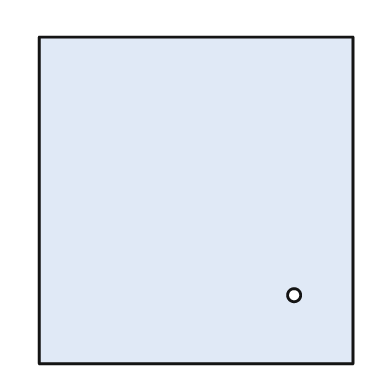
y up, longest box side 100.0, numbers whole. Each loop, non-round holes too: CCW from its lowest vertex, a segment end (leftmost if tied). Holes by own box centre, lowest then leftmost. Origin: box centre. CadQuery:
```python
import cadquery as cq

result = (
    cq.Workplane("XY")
    .moveTo(-48.0, -50.0)
    .lineTo(48.0, -50.0)
    .lineTo(48.0, 50.0)
    .lineTo(-48.0, 50.0)
    .close()
    .moveTo(30.0, -29.0)
    .circle(2.0)
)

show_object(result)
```